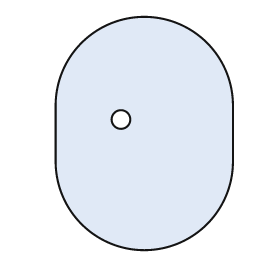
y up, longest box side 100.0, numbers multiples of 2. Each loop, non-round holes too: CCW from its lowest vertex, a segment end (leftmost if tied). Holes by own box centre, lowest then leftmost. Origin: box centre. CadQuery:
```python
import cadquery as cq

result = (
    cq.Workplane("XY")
    .moveTo(-38.0, -12.0)
    .threePointArc((0.0, -50.0), (38.0, -12.0))
    .lineTo(38.0, 12.0)
    .threePointArc((0.0, 50.0), (-38.0, 12.0))
    .close()
    .moveTo(-10.0, 6.0)
    .circle(4.0)
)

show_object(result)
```